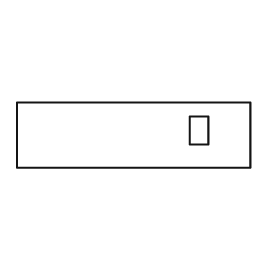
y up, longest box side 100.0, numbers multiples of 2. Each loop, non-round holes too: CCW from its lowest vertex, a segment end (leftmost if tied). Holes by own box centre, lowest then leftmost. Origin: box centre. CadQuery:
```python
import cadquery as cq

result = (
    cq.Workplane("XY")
    .moveTo(-50.0, -14.0)
    .lineTo(50.0, -14.0)
    .lineTo(50.0, 14.0)
    .lineTo(-50.0, 14.0)
    .close()
    .moveTo(24.0, -4.0)
    .lineTo(32.0, -4.0)
    .lineTo(32.0, 8.0)
    .lineTo(24.0, 8.0)
    .close()
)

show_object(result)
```